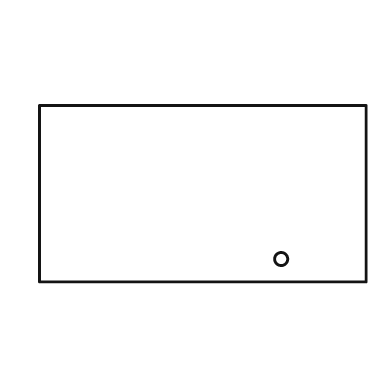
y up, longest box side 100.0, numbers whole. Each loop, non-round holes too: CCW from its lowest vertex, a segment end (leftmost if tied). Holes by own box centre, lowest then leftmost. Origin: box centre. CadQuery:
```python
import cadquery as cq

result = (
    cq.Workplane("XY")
    .moveTo(-50.0, -27.0)
    .lineTo(50.0, -27.0)
    .lineTo(50.0, 27.0)
    .lineTo(-50.0, 27.0)
    .close()
    .moveTo(24.0, -20.0)
    .circle(2.0)
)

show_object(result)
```